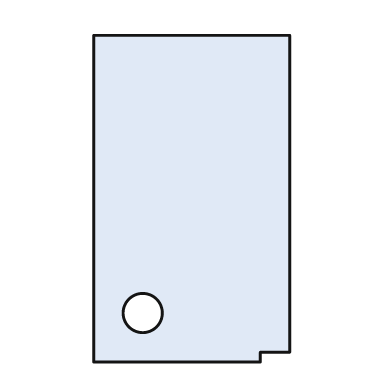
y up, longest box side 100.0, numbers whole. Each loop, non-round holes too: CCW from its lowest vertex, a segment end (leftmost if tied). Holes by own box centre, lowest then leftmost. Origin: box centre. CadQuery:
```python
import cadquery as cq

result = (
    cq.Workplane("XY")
    .moveTo(-30.0, -50.0)
    .lineTo(21.0, -50.0)
    .lineTo(21.0, -47.0)
    .lineTo(30.0, -47.0)
    .lineTo(30.0, 50.0)
    .lineTo(-30.0, 50.0)
    .close()
    .moveTo(-15.0, -35.0)
    .circle(6.0)
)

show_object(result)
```